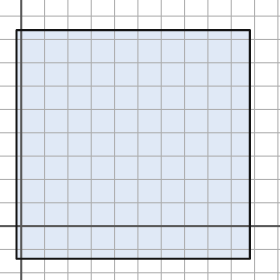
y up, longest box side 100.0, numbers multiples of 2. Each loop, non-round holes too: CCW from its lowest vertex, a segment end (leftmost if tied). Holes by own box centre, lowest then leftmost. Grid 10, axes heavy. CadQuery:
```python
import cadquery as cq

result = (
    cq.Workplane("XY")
    .moveTo(-2.0, -14.0)
    .lineTo(98.0, -14.0)
    .lineTo(98.0, 84.0)
    .lineTo(-2.0, 84.0)
    .close()
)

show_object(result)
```